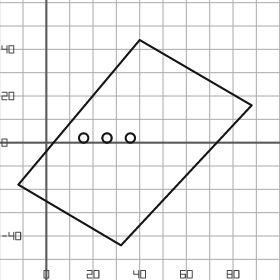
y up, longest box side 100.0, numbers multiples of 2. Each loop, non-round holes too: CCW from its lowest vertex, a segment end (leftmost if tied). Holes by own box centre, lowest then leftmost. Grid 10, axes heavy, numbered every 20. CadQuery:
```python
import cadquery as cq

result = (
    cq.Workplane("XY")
    .moveTo(32.0, -44.0)
    .lineTo(88.0, 16.0)
    .lineTo(40.0, 44.0)
    .lineTo(-12.0, -18.0)
    .close()
    .moveTo(16.0, 2.0)
    .circle(2.0)
    .moveTo(26.0, 2.0)
    .circle(2.0)
    .moveTo(36.0, 2.0)
    .circle(2.0)
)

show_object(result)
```